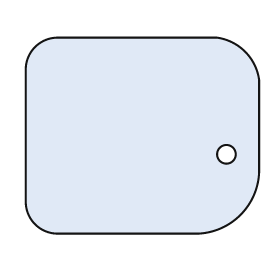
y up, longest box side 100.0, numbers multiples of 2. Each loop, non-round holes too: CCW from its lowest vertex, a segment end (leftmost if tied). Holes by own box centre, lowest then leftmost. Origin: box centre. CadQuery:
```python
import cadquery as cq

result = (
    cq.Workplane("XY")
    .moveTo(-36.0, -42.0)
    .lineTo(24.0, -42.0)
    .threePointArc((42.0, -34.0), (50.0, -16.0))
    .lineTo(50.0, 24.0)
    .threePointArc((44.0, 36.0), (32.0, 42.0))
    .lineTo(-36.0, 42.0)
    .threePointArc((-46.0, 38.0), (-50.0, 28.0))
    .lineTo(-50.0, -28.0)
    .threePointArc((-46.0, -38.0), (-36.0, -42.0))
    .close()
    .moveTo(36.0, -8.0)
    .circle(4.0)
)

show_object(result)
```